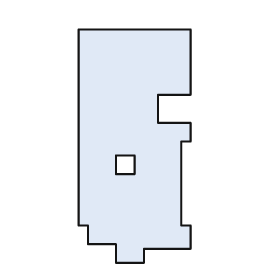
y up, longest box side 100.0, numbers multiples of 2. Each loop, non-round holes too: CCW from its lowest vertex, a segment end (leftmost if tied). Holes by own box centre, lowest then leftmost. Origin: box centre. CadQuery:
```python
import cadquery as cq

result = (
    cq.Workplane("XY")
    .moveTo(-8.0, -50.0)
    .lineTo(4.0, -50.0)
    .lineTo(4.0, -44.0)
    .lineTo(24.0, -44.0)
    .lineTo(24.0, -34.0)
    .lineTo(20.0, -34.0)
    .lineTo(20.0, 2.0)
    .lineTo(24.0, 2.0)
    .lineTo(24.0, 10.0)
    .lineTo(10.0, 10.0)
    .lineTo(10.0, 22.0)
    .lineTo(24.0, 22.0)
    .lineTo(24.0, 50.0)
    .lineTo(-24.0, 50.0)
    .lineTo(-24.0, -34.0)
    .lineTo(-20.0, -34.0)
    .lineTo(-20.0, -42.0)
    .lineTo(-8.0, -42.0)
    .close()
    .moveTo(-8.0, -12.0)
    .lineTo(0.0, -12.0)
    .lineTo(0.0, -4.0)
    .lineTo(-8.0, -4.0)
    .close()
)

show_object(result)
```